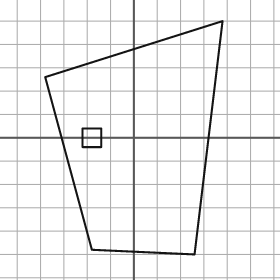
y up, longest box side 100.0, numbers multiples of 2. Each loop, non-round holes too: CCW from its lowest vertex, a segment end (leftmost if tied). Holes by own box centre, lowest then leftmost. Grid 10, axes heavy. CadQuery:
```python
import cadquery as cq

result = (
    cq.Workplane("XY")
    .moveTo(26.0, -50.0)
    .lineTo(38.0, 50.0)
    .lineTo(-38.0, 26.0)
    .lineTo(-18.0, -48.0)
    .close()
    .moveTo(-22.0, -4.0)
    .lineTo(-14.0, -4.0)
    .lineTo(-14.0, 4.0)
    .lineTo(-22.0, 4.0)
    .close()
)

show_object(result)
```